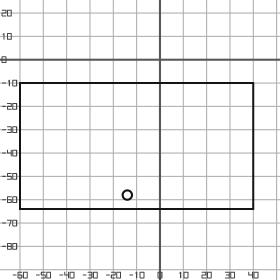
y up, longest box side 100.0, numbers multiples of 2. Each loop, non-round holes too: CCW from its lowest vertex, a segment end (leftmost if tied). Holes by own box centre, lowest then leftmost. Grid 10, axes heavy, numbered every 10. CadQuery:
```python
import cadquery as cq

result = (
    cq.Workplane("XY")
    .moveTo(-60.0, -64.0)
    .lineTo(40.0, -64.0)
    .lineTo(40.0, -10.0)
    .lineTo(-60.0, -10.0)
    .close()
    .moveTo(-14.0, -58.0)
    .circle(2.0)
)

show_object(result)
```